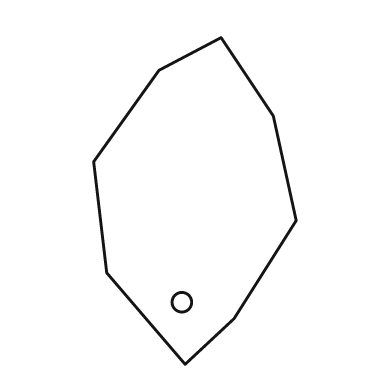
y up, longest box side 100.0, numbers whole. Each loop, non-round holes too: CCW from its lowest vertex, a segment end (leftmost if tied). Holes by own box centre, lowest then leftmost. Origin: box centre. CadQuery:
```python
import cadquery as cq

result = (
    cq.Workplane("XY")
    .moveTo(-3.0, -50.0)
    .lineTo(12.0, -36.0)
    .lineTo(31.0, -6.0)
    .lineTo(24.0, 26.0)
    .lineTo(8.0, 50.0)
    .lineTo(-11.0, 40.0)
    .lineTo(-31.0, 12.0)
    .lineTo(-27.0, -22.0)
    .close()
    .moveTo(-4.0, -31.0)
    .circle(3.0)
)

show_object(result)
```